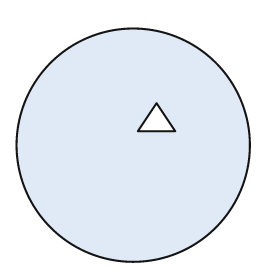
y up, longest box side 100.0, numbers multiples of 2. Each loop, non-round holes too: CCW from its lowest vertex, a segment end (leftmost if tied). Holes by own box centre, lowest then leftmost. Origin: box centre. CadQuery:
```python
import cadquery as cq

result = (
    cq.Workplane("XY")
    .moveTo(0.0, 0.0)
    .circle(50.0)
    .moveTo(2.0, 6.0)
    .lineTo(18.0, 6.0)
    .lineTo(10.0, 18.0)
    .close()
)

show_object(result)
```